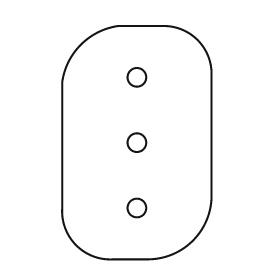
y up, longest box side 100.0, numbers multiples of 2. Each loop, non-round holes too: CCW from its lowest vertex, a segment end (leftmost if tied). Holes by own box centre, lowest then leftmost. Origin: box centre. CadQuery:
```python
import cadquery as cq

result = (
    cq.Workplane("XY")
    .moveTo(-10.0, -50.0)
    .lineTo(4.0, -50.0)
    .threePointArc((24.0, -42.0), (32.0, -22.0))
    .lineTo(32.0, 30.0)
    .threePointArc((26.0, 44.0), (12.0, 50.0))
    .lineTo(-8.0, 50.0)
    .threePointArc((-24.0, 42.0), (-32.0, 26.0))
    .lineTo(-32.0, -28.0)
    .threePointArc((-26.0, -44.0), (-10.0, -50.0))
    .close()
    .moveTo(0.0, -28.0)
    .circle(4.0)
    .moveTo(0.0, 0.0)
    .circle(4.0)
    .moveTo(0.0, 28.0)
    .circle(4.0)
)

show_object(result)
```